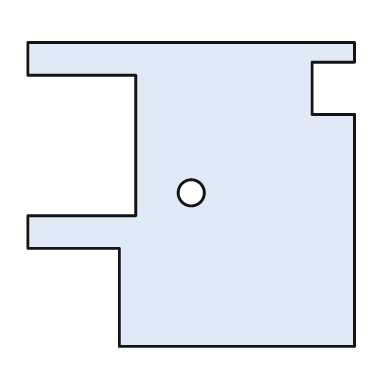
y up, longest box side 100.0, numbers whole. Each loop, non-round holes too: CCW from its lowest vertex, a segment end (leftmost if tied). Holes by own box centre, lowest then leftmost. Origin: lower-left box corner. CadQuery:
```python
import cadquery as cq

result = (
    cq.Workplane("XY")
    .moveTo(28.0, 0.0)
    .lineTo(100.0, 0.0)
    .lineTo(100.0, 71.0)
    .lineTo(87.0, 71.0)
    .lineTo(87.0, 87.0)
    .lineTo(100.0, 87.0)
    .lineTo(100.0, 93.0)
    .lineTo(0.0, 93.0)
    .lineTo(0.0, 83.0)
    .lineTo(33.0, 83.0)
    .lineTo(33.0, 40.0)
    .lineTo(0.0, 40.0)
    .lineTo(0.0, 30.0)
    .lineTo(28.0, 30.0)
    .close()
    .moveTo(50.0, 47.0)
    .circle(4.0)
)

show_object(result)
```